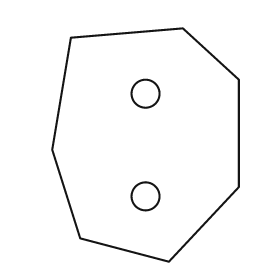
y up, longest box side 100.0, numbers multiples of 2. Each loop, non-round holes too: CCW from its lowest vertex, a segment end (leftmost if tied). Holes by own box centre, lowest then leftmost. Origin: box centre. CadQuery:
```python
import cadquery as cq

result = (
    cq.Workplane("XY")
    .moveTo(10.0, -50.0)
    .lineTo(40.0, -18.0)
    .lineTo(40.0, 28.0)
    .lineTo(16.0, 50.0)
    .lineTo(-32.0, 46.0)
    .lineTo(-40.0, -2.0)
    .lineTo(-28.0, -40.0)
    .close()
    .moveTo(0.0, -22.0)
    .circle(6.0)
    .moveTo(0.0, 22.0)
    .circle(6.0)
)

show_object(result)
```